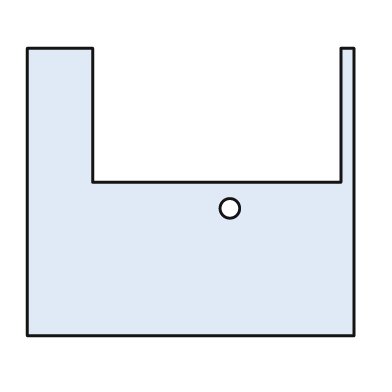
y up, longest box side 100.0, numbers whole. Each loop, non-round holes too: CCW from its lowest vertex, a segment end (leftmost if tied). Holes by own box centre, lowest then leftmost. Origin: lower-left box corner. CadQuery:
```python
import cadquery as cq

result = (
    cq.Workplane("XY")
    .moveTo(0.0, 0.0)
    .lineTo(100.0, 0.0)
    .lineTo(100.0, 88.0)
    .lineTo(96.0, 88.0)
    .lineTo(96.0, 47.0)
    .lineTo(20.0, 47.0)
    .lineTo(20.0, 88.0)
    .lineTo(0.0, 88.0)
    .close()
    .moveTo(62.0, 39.0)
    .circle(3.0)
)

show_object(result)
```